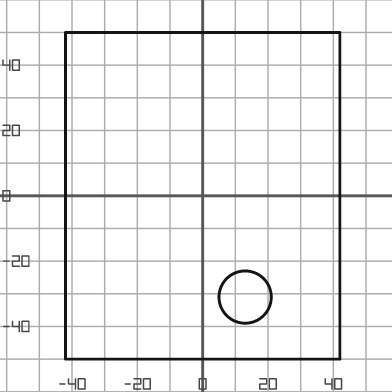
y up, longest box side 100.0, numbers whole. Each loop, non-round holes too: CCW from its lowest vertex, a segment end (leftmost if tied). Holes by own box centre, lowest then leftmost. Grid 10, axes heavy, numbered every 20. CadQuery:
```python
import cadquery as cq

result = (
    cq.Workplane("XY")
    .moveTo(-42.0, -50.0)
    .lineTo(42.0, -50.0)
    .lineTo(42.0, 50.0)
    .lineTo(-42.0, 50.0)
    .close()
    .moveTo(13.0, -31.0)
    .circle(8.0)
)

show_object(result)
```